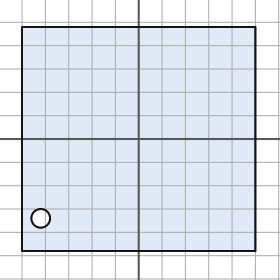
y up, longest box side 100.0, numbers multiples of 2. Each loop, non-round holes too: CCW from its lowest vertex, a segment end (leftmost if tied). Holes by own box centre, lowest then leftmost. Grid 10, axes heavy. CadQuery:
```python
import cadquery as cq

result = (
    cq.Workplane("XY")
    .moveTo(-50.0, -48.0)
    .lineTo(50.0, -48.0)
    .lineTo(50.0, 48.0)
    .lineTo(-50.0, 48.0)
    .close()
    .moveTo(-42.0, -34.0)
    .circle(4.0)
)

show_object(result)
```